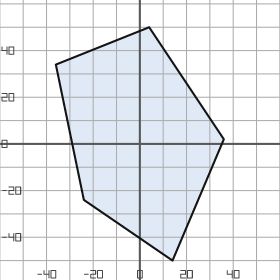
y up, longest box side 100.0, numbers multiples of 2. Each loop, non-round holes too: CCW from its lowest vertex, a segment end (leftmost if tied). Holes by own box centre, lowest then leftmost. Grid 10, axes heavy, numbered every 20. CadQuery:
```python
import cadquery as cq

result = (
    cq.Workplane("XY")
    .moveTo(14.0, -50.0)
    .lineTo(36.0, 2.0)
    .lineTo(4.0, 50.0)
    .lineTo(-36.0, 34.0)
    .lineTo(-24.0, -24.0)
    .close()
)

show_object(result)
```